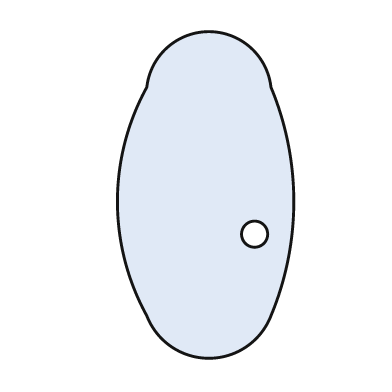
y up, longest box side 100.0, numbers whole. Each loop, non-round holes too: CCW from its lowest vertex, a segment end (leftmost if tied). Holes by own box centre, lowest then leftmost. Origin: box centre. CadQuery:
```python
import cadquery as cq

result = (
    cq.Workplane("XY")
    .moveTo(-18.0, -37.0)
    .threePointArc((1.0, -50.0), (20.0, -37.0))
    .threePointArc((27.0, -2.0), (20.0, 33.0))
    .threePointArc((1.0, 50.0), (-18.0, 33.0))
    .threePointArc((-27.0, -2.0), (-18.0, -37.0))
    .close()
    .moveTo(15.0, -12.0)
    .circle(4.0)
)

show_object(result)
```